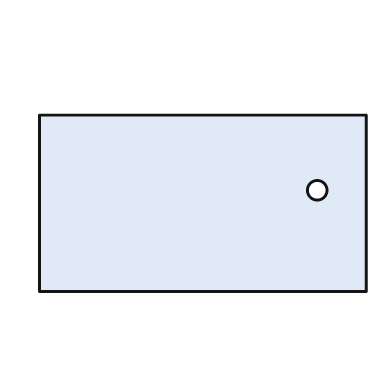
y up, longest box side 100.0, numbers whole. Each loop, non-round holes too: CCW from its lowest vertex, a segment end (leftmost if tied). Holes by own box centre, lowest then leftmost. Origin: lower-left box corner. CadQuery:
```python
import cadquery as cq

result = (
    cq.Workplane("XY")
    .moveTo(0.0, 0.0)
    .lineTo(100.0, 0.0)
    .lineTo(100.0, 54.0)
    .lineTo(0.0, 54.0)
    .close()
    .moveTo(85.0, 31.0)
    .circle(3.0)
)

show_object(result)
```